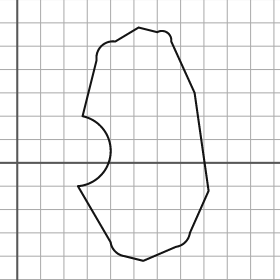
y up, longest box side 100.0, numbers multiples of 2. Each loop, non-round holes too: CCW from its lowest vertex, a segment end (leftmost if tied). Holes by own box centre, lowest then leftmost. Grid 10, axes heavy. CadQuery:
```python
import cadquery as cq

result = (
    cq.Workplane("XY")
    .moveTo(54.0, -42.0)
    .lineTo(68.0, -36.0)
    .threePointArc((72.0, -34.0), (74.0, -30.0))
    .lineTo(82.0, -12.0)
    .lineTo(76.0, 30.0)
    .lineTo(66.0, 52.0)
    .threePointArc((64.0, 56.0), (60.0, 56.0))
    .lineTo(52.0, 58.0)
    .lineTo(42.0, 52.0)
    .threePointArc((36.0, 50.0), (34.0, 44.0))
    .lineTo(28.0, 20.0)
    .threePointArc((40.0, 4.0), (26.0, -10.0))
    .lineTo(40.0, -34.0)
    .threePointArc((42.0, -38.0), (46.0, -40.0))
    .close()
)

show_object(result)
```